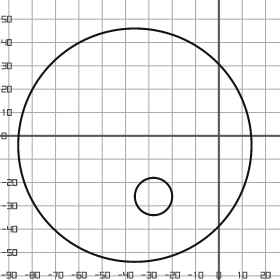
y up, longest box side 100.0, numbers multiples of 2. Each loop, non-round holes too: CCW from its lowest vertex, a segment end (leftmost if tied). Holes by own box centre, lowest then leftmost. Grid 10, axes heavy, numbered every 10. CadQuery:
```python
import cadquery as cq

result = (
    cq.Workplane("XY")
    .moveTo(-36.0, -4.0)
    .circle(50.0)
    .moveTo(-28.0, -26.0)
    .circle(8.0)
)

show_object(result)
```